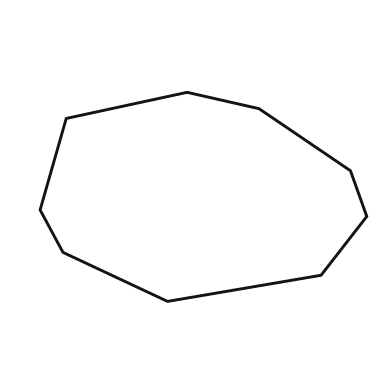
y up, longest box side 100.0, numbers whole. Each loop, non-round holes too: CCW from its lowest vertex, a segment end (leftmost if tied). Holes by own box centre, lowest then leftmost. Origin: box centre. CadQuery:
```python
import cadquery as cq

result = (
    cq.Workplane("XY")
    .moveTo(-11.0, -32.0)
    .lineTo(36.0, -24.0)
    .lineTo(50.0, -6.0)
    .lineTo(45.0, 8.0)
    .lineTo(17.0, 27.0)
    .lineTo(-5.0, 32.0)
    .lineTo(-42.0, 24.0)
    .lineTo(-50.0, -4.0)
    .lineTo(-43.0, -17.0)
    .close()
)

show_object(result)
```